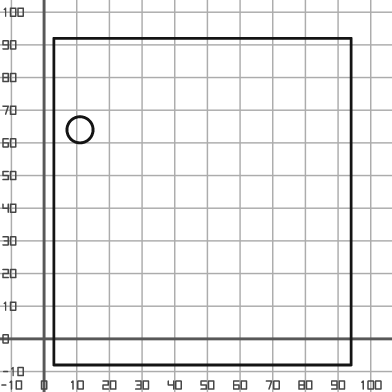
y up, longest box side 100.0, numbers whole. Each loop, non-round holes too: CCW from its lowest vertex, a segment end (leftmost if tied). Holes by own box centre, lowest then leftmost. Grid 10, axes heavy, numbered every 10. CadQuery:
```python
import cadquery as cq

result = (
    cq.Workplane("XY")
    .moveTo(3.0, -8.0)
    .lineTo(94.0, -8.0)
    .lineTo(94.0, 92.0)
    .lineTo(3.0, 92.0)
    .close()
    .moveTo(11.0, 64.0)
    .circle(4.0)
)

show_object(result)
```